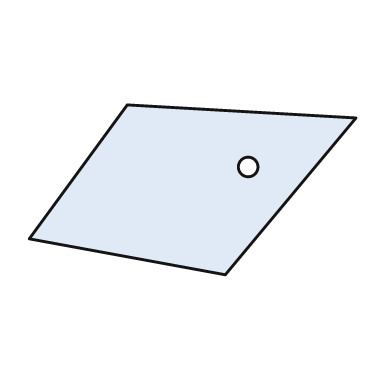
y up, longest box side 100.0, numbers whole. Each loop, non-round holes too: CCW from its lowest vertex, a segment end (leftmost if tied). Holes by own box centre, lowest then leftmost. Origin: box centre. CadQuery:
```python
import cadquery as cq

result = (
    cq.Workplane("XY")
    .moveTo(10.0, -26.0)
    .lineTo(50.0, 22.0)
    .lineTo(-20.0, 26.0)
    .lineTo(-50.0, -15.0)
    .close()
    .moveTo(17.0, 7.0)
    .circle(3.0)
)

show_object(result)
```